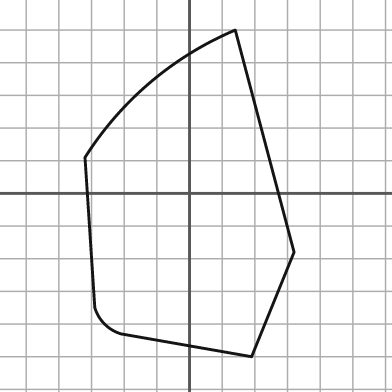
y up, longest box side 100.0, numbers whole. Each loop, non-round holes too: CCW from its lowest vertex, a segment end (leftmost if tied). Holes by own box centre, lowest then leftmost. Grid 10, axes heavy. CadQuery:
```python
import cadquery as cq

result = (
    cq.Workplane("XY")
    .moveTo(19.0, -50.0)
    .lineTo(32.0, -18.0)
    .lineTo(14.0, 50.0)
    .threePointArc((-12.0, 34.0), (-32.0, 11.0))
    .lineTo(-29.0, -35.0)
    .threePointArc((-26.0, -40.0), (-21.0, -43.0))
    .close()
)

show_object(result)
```